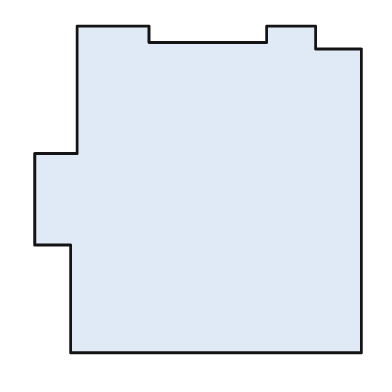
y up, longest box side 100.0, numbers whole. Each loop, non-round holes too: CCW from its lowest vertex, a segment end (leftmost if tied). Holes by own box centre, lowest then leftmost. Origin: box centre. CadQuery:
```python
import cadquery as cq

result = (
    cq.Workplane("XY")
    .moveTo(-39.0, -50.0)
    .lineTo(50.0, -50.0)
    .lineTo(50.0, 43.0)
    .lineTo(36.0, 43.0)
    .lineTo(36.0, 50.0)
    .lineTo(21.0, 50.0)
    .lineTo(21.0, 45.0)
    .lineTo(-15.0, 45.0)
    .lineTo(-15.0, 50.0)
    .lineTo(-37.0, 50.0)
    .lineTo(-37.0, 11.0)
    .lineTo(-50.0, 11.0)
    .lineTo(-50.0, -17.0)
    .lineTo(-39.0, -17.0)
    .close()
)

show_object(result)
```